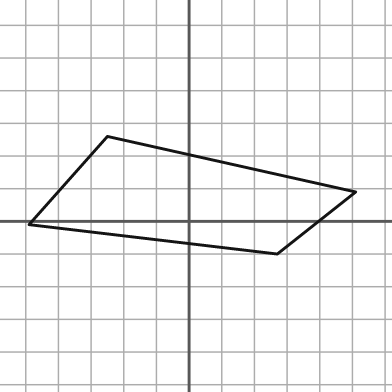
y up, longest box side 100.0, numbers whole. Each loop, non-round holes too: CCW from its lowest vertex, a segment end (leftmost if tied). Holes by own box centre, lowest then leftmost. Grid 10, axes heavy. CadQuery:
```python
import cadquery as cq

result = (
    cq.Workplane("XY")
    .moveTo(27.0, -10.0)
    .lineTo(51.0, 9.0)
    .lineTo(-25.0, 26.0)
    .lineTo(-49.0, -1.0)
    .close()
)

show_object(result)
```